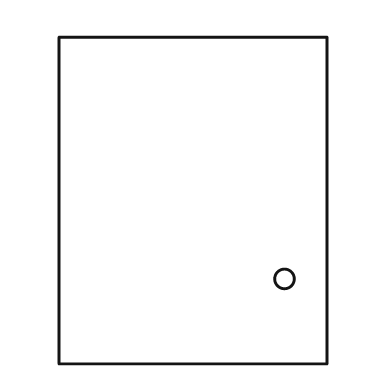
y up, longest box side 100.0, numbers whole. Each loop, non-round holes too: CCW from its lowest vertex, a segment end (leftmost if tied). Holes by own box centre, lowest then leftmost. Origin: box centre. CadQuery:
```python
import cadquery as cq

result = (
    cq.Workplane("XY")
    .moveTo(-41.0, -50.0)
    .lineTo(41.0, -50.0)
    .lineTo(41.0, 50.0)
    .lineTo(-41.0, 50.0)
    .close()
    .moveTo(28.0, -24.0)
    .circle(3.0)
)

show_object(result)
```